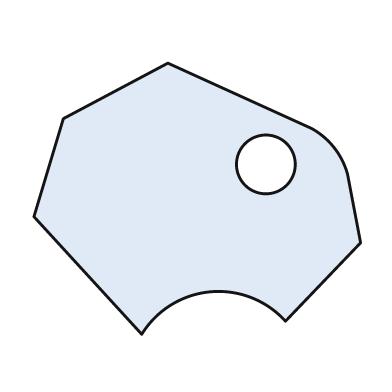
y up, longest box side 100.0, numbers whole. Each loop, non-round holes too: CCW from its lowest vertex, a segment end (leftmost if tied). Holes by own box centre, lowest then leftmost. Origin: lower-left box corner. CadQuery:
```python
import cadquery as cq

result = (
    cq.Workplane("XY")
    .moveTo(33.0, 0.0)
    .threePointArc((54.0, 13.0), (77.0, 4.0))
    .lineTo(100.0, 28.0)
    .lineTo(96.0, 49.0)
    .threePointArc((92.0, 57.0), (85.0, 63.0))
    .lineTo(41.0, 83.0)
    .lineTo(9.0, 66.0)
    .lineTo(0.0, 36.0)
    .close()
    .moveTo(71.0, 52.0)
    .circle(9.0)
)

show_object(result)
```